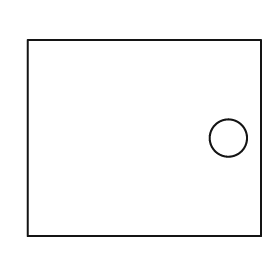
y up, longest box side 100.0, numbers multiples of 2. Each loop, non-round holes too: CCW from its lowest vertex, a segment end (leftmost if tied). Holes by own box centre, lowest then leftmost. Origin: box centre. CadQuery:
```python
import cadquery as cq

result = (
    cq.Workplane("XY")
    .moveTo(-50.0, -42.0)
    .lineTo(50.0, -42.0)
    .lineTo(50.0, 42.0)
    .lineTo(-50.0, 42.0)
    .close()
    .moveTo(36.0, 0.0)
    .circle(8.0)
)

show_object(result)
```